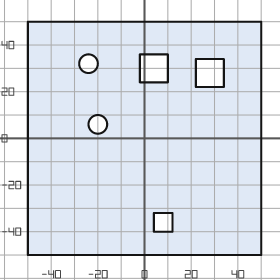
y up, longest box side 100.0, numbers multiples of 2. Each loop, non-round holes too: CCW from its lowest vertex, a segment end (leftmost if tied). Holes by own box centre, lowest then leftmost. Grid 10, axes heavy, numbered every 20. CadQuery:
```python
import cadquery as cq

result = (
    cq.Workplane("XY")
    .moveTo(-50.0, -50.0)
    .lineTo(50.0, -50.0)
    .lineTo(50.0, 50.0)
    .lineTo(-50.0, 50.0)
    .close()
    .moveTo(4.0, -40.0)
    .lineTo(12.0, -40.0)
    .lineTo(12.0, -32.0)
    .lineTo(4.0, -32.0)
    .close()
    .moveTo(-20.0, 6.0)
    .circle(4.0)
    .moveTo(22.0, 22.0)
    .lineTo(34.0, 22.0)
    .lineTo(34.0, 34.0)
    .lineTo(22.0, 34.0)
    .close()
    .moveTo(-2.0, 24.0)
    .lineTo(10.0, 24.0)
    .lineTo(10.0, 36.0)
    .lineTo(-2.0, 36.0)
    .close()
    .moveTo(-24.0, 32.0)
    .circle(4.0)
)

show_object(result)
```